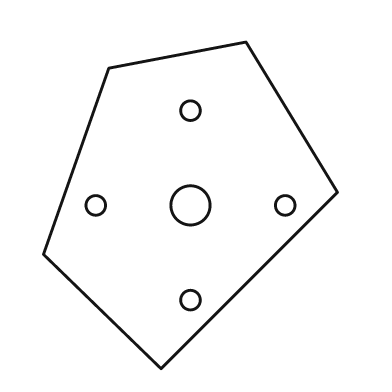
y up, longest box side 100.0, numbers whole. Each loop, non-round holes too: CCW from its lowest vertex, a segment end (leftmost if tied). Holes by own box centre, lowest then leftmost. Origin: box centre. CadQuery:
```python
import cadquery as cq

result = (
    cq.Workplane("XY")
    .moveTo(-9.0, -50.0)
    .lineTo(45.0, 4.0)
    .lineTo(17.0, 50.0)
    .lineTo(-25.0, 42.0)
    .lineTo(-45.0, -15.0)
    .close()
    .moveTo(0.0, -29.0)
    .circle(3.0)
    .moveTo(-29.0, 0.0)
    .circle(3.0)
    .moveTo(0.0, 0.0)
    .circle(6.0)
    .moveTo(29.0, 0.0)
    .circle(3.0)
    .moveTo(0.0, 29.0)
    .circle(3.0)
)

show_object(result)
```